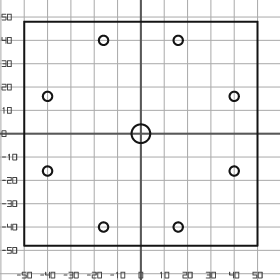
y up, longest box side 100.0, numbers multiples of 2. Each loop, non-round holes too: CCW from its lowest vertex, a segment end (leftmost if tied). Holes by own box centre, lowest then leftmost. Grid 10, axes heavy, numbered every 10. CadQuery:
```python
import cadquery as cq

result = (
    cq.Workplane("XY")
    .moveTo(-50.0, -48.0)
    .lineTo(50.0, -48.0)
    .lineTo(50.0, 48.0)
    .lineTo(-50.0, 48.0)
    .close()
    .moveTo(-16.0, -40.0)
    .circle(2.0)
    .moveTo(16.0, -40.0)
    .circle(2.0)
    .moveTo(-40.0, -16.0)
    .circle(2.0)
    .moveTo(40.0, -16.0)
    .circle(2.0)
    .moveTo(0.0, 0.0)
    .circle(4.0)
    .moveTo(-40.0, 16.0)
    .circle(2.0)
    .moveTo(40.0, 16.0)
    .circle(2.0)
    .moveTo(-16.0, 40.0)
    .circle(2.0)
    .moveTo(16.0, 40.0)
    .circle(2.0)
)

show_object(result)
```